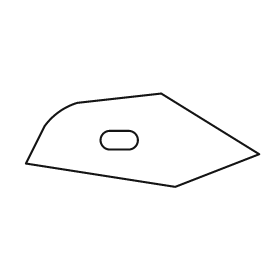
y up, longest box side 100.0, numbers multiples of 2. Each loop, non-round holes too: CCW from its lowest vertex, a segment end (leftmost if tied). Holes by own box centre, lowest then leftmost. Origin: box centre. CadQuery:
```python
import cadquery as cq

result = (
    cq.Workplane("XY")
    .moveTo(14.0, -20.0)
    .lineTo(50.0, -6.0)
    .lineTo(8.0, 20.0)
    .lineTo(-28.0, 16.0)
    .threePointArc((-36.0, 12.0), (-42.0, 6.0))
    .lineTo(-50.0, -10.0)
    .close()
    .moveTo(-14.0, -4.0)
    .lineTo(-6.0, -4.0)
    .threePointArc((-2.0, 0.0), (-6.0, 4.0))
    .lineTo(-14.0, 4.0)
    .threePointArc((-18.0, 0.0), (-14.0, -4.0))
    .close()
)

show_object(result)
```